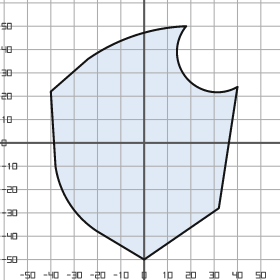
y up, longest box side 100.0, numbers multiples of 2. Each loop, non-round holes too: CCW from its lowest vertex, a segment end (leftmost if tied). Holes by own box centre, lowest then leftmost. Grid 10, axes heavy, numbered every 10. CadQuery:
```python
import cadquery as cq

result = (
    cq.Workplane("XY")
    .moveTo(0.0, -50.0)
    .lineTo(32.0, -28.0)
    .lineTo(40.0, 24.0)
    .threePointArc((18.0, 28.0), (18.0, 50.0))
    .threePointArc((-4.0, 46.0), (-24.0, 36.0))
    .lineTo(-40.0, 22.0)
    .lineTo(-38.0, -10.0)
    .threePointArc((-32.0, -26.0), (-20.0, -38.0))
    .close()
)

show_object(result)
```